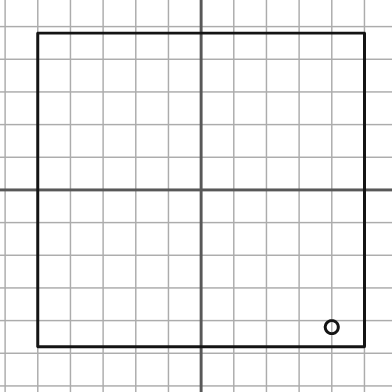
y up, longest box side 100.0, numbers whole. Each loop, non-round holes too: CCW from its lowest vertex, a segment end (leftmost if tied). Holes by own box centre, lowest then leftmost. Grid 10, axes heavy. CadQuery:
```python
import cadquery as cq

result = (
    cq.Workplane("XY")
    .moveTo(-50.0, -48.0)
    .lineTo(50.0, -48.0)
    .lineTo(50.0, 48.0)
    .lineTo(-50.0, 48.0)
    .close()
    .moveTo(40.0, -42.0)
    .circle(2.0)
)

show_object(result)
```